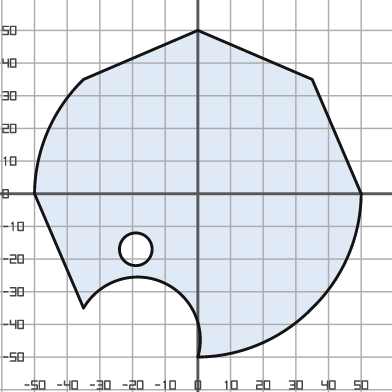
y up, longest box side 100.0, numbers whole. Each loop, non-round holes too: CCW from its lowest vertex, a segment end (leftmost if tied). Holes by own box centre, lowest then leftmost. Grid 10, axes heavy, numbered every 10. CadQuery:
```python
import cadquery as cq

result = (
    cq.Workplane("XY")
    .moveTo(0.0, -50.0)
    .threePointArc((19.0, -46.0), (35.0, -35.0))
    .threePointArc((46.0, -19.0), (50.0, 0.0))
    .lineTo(35.0, 35.0)
    .lineTo(0.0, 50.0)
    .lineTo(-35.0, 35.0)
    .threePointArc((-46.0, 19.0), (-50.0, 0.0))
    .lineTo(-35.0, -35.0)
    .threePointArc((-11.0, -27.0), (0.0, -50.0))
    .close()
    .moveTo(-19.0, -17.0)
    .circle(5.0)
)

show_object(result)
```